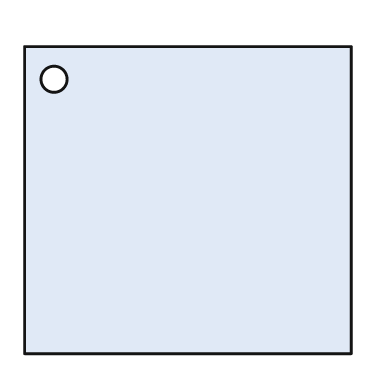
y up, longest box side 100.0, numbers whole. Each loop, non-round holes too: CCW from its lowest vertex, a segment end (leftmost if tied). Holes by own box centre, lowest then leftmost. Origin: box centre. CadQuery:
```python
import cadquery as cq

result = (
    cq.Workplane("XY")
    .moveTo(-50.0, -47.0)
    .lineTo(50.0, -47.0)
    .lineTo(50.0, 47.0)
    .lineTo(-50.0, 47.0)
    .close()
    .moveTo(-41.0, 37.0)
    .circle(4.0)
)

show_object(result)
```